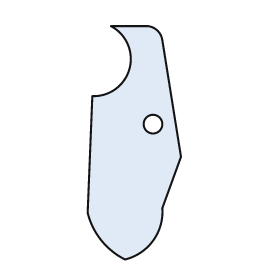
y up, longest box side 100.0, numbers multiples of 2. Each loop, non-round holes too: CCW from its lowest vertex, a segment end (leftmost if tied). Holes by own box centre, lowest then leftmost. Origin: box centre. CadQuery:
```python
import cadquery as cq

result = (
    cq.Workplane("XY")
    .moveTo(-4.0, -50.0)
    .threePointArc((8.0, -42.0), (12.0, -28.0))
    .lineTo(20.0, -6.0)
    .lineTo(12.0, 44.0)
    .threePointArc((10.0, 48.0), (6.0, 50.0))
    .lineTo(-10.0, 50.0)
    .threePointArc((-2.0, 32.0), (-18.0, 20.0))
    .lineTo(-20.0, -30.0)
    .threePointArc((-14.0, -42.0), (-4.0, -50.0))
    .close()
    .moveTo(8.0, 8.0)
    .circle(4.0)
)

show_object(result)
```